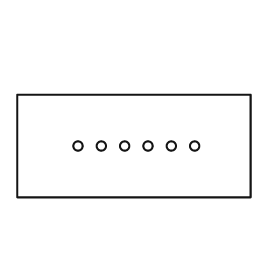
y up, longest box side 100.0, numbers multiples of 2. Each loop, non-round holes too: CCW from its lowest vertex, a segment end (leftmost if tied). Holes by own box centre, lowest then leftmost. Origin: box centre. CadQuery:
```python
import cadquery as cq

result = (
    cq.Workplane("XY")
    .moveTo(-50.0, -22.0)
    .lineTo(50.0, -22.0)
    .lineTo(50.0, 22.0)
    .lineTo(-50.0, 22.0)
    .close()
    .moveTo(-24.0, 0.0)
    .circle(2.0)
    .moveTo(-14.0, 0.0)
    .circle(2.0)
    .moveTo(-4.0, 0.0)
    .circle(2.0)
    .moveTo(6.0, 0.0)
    .circle(2.0)
    .moveTo(16.0, 0.0)
    .circle(2.0)
    .moveTo(26.0, 0.0)
    .circle(2.0)
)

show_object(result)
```